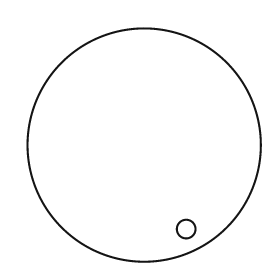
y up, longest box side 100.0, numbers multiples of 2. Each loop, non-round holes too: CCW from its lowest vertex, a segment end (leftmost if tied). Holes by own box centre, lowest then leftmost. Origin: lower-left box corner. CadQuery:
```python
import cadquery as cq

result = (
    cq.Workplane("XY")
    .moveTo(50.0, 50.0)
    .circle(50.0)
    .moveTo(68.0, 14.0)
    .circle(4.0)
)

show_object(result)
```